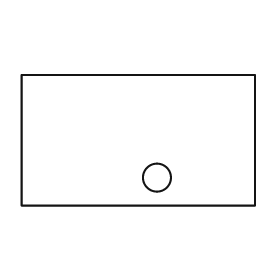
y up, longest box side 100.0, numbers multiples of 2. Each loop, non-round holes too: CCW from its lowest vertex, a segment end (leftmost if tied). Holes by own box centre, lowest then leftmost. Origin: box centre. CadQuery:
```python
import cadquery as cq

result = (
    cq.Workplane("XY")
    .moveTo(-50.0, -28.0)
    .lineTo(50.0, -28.0)
    .lineTo(50.0, 28.0)
    .lineTo(-50.0, 28.0)
    .close()
    .moveTo(8.0, -16.0)
    .circle(6.0)
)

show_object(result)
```